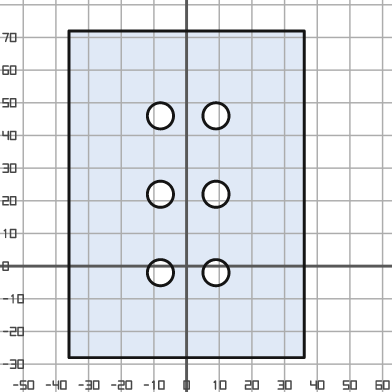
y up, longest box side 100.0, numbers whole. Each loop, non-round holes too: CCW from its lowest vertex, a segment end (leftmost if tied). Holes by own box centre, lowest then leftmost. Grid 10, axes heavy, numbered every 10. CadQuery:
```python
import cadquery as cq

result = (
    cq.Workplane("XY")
    .moveTo(-36.0, -28.0)
    .lineTo(36.0, -28.0)
    .lineTo(36.0, 72.0)
    .lineTo(-36.0, 72.0)
    .close()
    .moveTo(-8.0, -2.0)
    .circle(4.0)
    .moveTo(9.0, -2.0)
    .circle(4.0)
    .moveTo(-8.0, 22.0)
    .circle(4.0)
    .moveTo(9.0, 22.0)
    .circle(4.0)
    .moveTo(-8.0, 46.0)
    .circle(4.0)
    .moveTo(9.0, 46.0)
    .circle(4.0)
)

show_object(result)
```